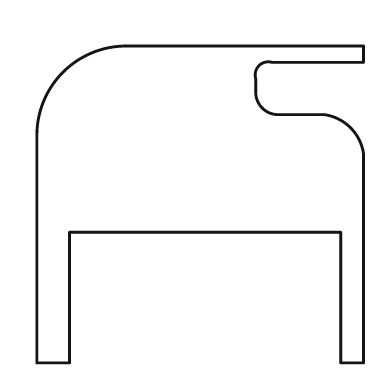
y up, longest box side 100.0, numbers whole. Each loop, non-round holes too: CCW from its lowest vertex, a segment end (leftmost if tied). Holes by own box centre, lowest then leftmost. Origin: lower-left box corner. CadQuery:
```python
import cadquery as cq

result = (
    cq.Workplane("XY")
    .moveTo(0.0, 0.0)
    .lineTo(10.0, 0.0)
    .lineTo(10.0, 40.0)
    .lineTo(93.0, 40.0)
    .lineTo(93.0, 0.0)
    .lineTo(100.0, 0.0)
    .lineTo(100.0, 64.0)
    .threePointArc((96.0, 72.0), (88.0, 76.0))
    .lineTo(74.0, 76.0)
    .threePointArc((69.0, 78.0), (67.0, 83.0))
    .lineTo(67.0, 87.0)
    .threePointArc((68.0, 91.0), (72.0, 92.0))
    .lineTo(100.0, 92.0)
    .lineTo(100.0, 97.0)
    .lineTo(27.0, 97.0)
    .threePointArc((8.0, 89.0), (0.0, 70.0))
    .close()
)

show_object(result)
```